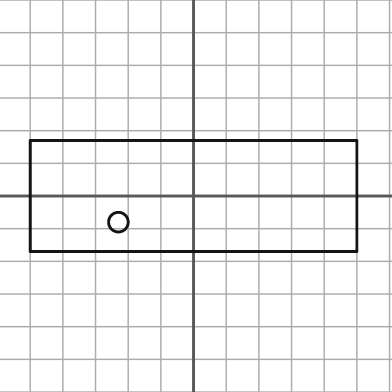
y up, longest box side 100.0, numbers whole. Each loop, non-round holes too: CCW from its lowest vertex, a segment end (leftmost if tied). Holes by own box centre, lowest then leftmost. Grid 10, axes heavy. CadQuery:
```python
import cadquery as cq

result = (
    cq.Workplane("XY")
    .moveTo(-50.0, -17.0)
    .lineTo(50.0, -17.0)
    .lineTo(50.0, 17.0)
    .lineTo(-50.0, 17.0)
    .close()
    .moveTo(-23.0, -8.0)
    .circle(3.0)
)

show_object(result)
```